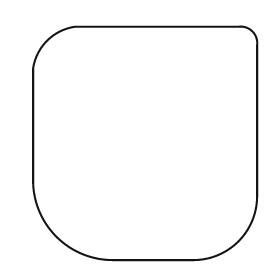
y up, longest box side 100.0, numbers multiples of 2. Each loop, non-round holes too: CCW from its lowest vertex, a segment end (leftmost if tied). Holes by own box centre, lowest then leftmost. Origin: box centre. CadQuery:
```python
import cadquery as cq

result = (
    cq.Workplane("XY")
    .moveTo(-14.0, -50.0)
    .lineTo(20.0, -50.0)
    .threePointArc((40.0, -42.0), (48.0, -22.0))
    .lineTo(48.0, 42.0)
    .threePointArc((46.0, 48.0), (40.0, 50.0))
    .lineTo(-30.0, 50.0)
    .threePointArc((-42.0, 44.0), (-48.0, 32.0))
    .lineTo(-48.0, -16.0)
    .threePointArc((-38.0, -40.0), (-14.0, -50.0))
    .close()
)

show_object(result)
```